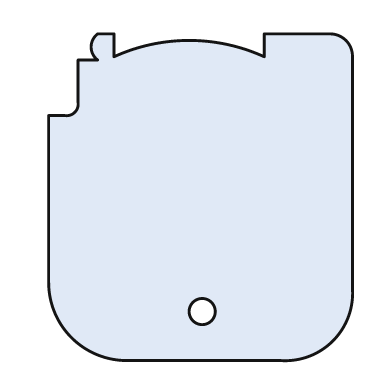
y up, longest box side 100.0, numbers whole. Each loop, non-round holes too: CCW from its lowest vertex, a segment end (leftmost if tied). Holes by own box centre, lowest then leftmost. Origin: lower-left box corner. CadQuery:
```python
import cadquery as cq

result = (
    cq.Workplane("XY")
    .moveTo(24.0, 0.0)
    .lineTo(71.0, 0.0)
    .threePointArc((87.0, 6.0), (93.0, 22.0))
    .lineTo(93.0, 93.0)
    .threePointArc((91.0, 98.0), (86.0, 100.0))
    .lineTo(66.0, 100.0)
    .lineTo(66.0, 93.0)
    .threePointArc((43.0, 98.0), (20.0, 93.0))
    .lineTo(20.0, 100.0)
    .lineTo(15.0, 100.0)
    .threePointArc((13.0, 96.0), (15.0, 92.0))
    .lineTo(9.0, 92.0)
    .lineTo(9.0, 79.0)
    .threePointArc((8.0, 76.0), (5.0, 75.0))
    .lineTo(0.0, 75.0)
    .lineTo(0.0, 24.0)
    .threePointArc((7.0, 7.0), (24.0, 0.0))
    .close()
    .moveTo(47.0, 15.0)
    .circle(4.0)
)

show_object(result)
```